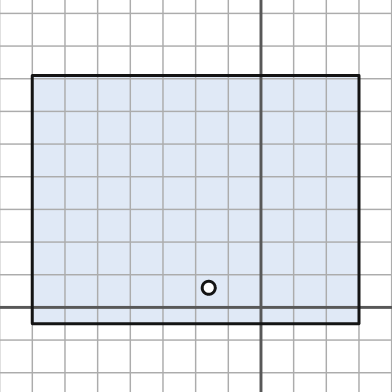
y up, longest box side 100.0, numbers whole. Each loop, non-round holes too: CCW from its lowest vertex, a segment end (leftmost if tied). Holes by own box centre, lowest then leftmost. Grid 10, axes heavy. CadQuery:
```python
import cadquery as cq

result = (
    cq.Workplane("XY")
    .moveTo(-70.0, -5.0)
    .lineTo(30.0, -5.0)
    .lineTo(30.0, 71.0)
    .lineTo(-70.0, 71.0)
    .close()
    .moveTo(-16.0, 6.0)
    .circle(2.0)
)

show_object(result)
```